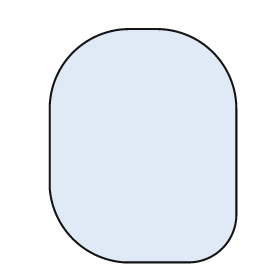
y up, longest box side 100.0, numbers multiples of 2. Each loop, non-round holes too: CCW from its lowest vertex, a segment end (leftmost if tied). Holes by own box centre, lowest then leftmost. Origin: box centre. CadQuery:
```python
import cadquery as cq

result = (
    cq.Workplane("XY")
    .moveTo(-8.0, -50.0)
    .lineTo(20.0, -50.0)
    .threePointArc((34.0, -44.0), (40.0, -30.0))
    .lineTo(40.0, 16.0)
    .threePointArc((30.0, 40.0), (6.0, 50.0))
    .lineTo(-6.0, 50.0)
    .threePointArc((-30.0, 40.0), (-40.0, 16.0))
    .lineTo(-40.0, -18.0)
    .threePointArc((-30.0, -40.0), (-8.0, -50.0))
    .close()
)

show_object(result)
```